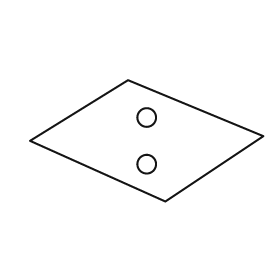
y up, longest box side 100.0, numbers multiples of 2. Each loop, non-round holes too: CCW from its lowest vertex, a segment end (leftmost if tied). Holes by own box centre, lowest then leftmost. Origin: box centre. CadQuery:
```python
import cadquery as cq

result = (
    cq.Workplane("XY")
    .moveTo(8.0, -26.0)
    .lineTo(50.0, 2.0)
    .lineTo(-8.0, 26.0)
    .lineTo(-50.0, 0.0)
    .close()
    .moveTo(0.0, -10.0)
    .circle(4.0)
    .moveTo(0.0, 10.0)
    .circle(4.0)
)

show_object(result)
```